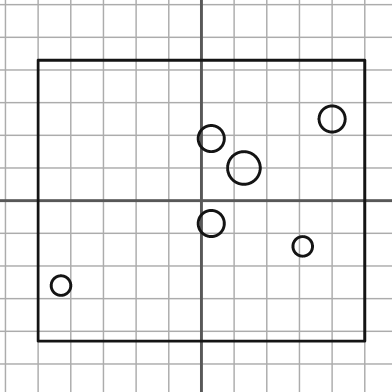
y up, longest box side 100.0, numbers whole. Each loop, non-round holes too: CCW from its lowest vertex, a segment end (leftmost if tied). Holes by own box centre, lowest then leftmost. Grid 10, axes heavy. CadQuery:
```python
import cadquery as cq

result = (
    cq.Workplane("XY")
    .moveTo(-50.0, -43.0)
    .lineTo(50.0, -43.0)
    .lineTo(50.0, 43.0)
    .lineTo(-50.0, 43.0)
    .close()
    .moveTo(-43.0, -26.0)
    .circle(3.0)
    .moveTo(31.0, -14.0)
    .circle(3.0)
    .moveTo(3.0, -7.0)
    .circle(4.0)
    .moveTo(13.0, 10.0)
    .circle(5.0)
    .moveTo(3.0, 19.0)
    .circle(4.0)
    .moveTo(40.0, 25.0)
    .circle(4.0)
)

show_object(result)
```